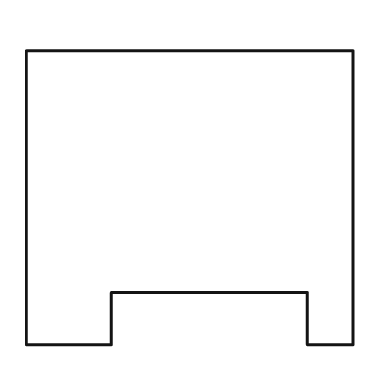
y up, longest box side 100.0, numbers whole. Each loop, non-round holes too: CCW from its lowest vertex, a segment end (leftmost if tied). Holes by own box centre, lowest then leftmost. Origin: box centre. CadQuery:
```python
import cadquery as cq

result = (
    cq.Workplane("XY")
    .moveTo(-50.0, -45.0)
    .lineTo(-24.0, -45.0)
    .lineTo(-24.0, -29.0)
    .lineTo(36.0, -29.0)
    .lineTo(36.0, -45.0)
    .lineTo(50.0, -45.0)
    .lineTo(50.0, 45.0)
    .lineTo(-50.0, 45.0)
    .close()
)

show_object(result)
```